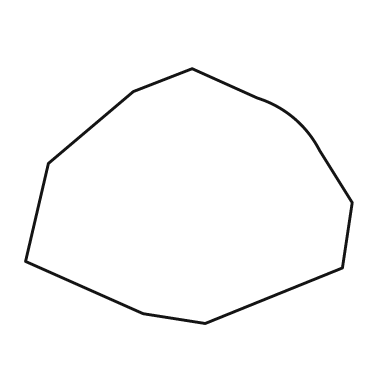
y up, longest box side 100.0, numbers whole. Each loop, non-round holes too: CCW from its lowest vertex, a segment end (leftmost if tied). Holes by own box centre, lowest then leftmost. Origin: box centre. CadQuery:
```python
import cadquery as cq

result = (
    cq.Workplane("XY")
    .moveTo(5.0, -39.0)
    .lineTo(47.0, -22.0)
    .lineTo(50.0, -2.0)
    .lineTo(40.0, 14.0)
    .threePointArc((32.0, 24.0), (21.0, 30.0))
    .lineTo(1.0, 39.0)
    .lineTo(-17.0, 32.0)
    .lineTo(-43.0, 10.0)
    .lineTo(-50.0, -20.0)
    .lineTo(-14.0, -36.0)
    .close()
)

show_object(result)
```